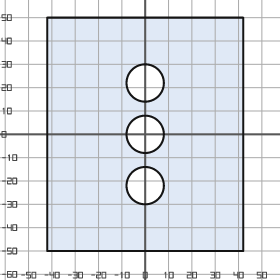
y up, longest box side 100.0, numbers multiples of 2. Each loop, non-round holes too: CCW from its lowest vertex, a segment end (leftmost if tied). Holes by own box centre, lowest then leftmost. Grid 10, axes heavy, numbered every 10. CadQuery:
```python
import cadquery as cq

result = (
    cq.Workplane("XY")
    .moveTo(-42.0, -50.0)
    .lineTo(42.0, -50.0)
    .lineTo(42.0, 50.0)
    .lineTo(-42.0, 50.0)
    .close()
    .moveTo(0.0, -22.0)
    .circle(8.0)
    .moveTo(0.0, 0.0)
    .circle(8.0)
    .moveTo(0.0, 22.0)
    .circle(8.0)
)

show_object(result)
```